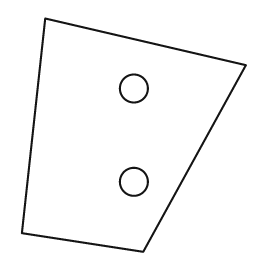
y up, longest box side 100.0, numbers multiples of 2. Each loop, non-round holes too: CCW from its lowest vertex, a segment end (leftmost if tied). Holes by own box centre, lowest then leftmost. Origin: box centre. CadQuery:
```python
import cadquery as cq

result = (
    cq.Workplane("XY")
    .moveTo(4.0, -50.0)
    .lineTo(48.0, 30.0)
    .lineTo(-38.0, 50.0)
    .lineTo(-48.0, -42.0)
    .close()
    .moveTo(0.0, -20.0)
    .circle(6.0)
    .moveTo(0.0, 20.0)
    .circle(6.0)
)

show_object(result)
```